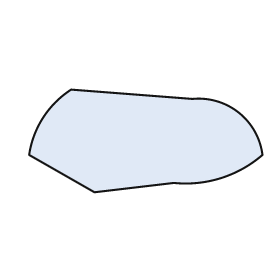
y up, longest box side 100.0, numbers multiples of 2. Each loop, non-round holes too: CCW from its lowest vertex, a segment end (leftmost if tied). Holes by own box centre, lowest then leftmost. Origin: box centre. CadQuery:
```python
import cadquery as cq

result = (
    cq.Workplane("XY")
    .moveTo(-22.0, -22.0)
    .lineTo(12.0, -18.0)
    .threePointArc((32.0, -16.0), (50.0, -6.0))
    .threePointArc((40.0, 12.0), (20.0, 18.0))
    .lineTo(-32.0, 22.0)
    .threePointArc((-44.0, 10.0), (-50.0, -6.0))
    .close()
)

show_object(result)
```